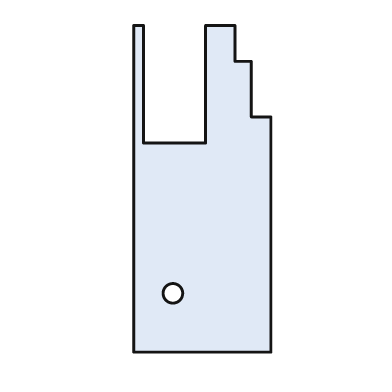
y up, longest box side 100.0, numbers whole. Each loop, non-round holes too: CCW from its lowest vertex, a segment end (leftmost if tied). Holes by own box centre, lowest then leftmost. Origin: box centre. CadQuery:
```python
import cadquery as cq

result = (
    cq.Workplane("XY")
    .moveTo(-21.0, -50.0)
    .lineTo(21.0, -50.0)
    .lineTo(21.0, 22.0)
    .lineTo(15.0, 22.0)
    .lineTo(15.0, 39.0)
    .lineTo(10.0, 39.0)
    .lineTo(10.0, 50.0)
    .lineTo(1.0, 50.0)
    .lineTo(1.0, 14.0)
    .lineTo(-18.0, 14.0)
    .lineTo(-18.0, 50.0)
    .lineTo(-21.0, 50.0)
    .close()
    .moveTo(-9.0, -32.0)
    .circle(3.0)
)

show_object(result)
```